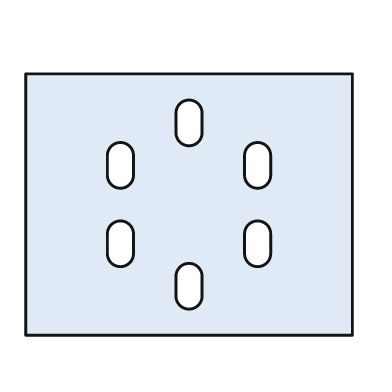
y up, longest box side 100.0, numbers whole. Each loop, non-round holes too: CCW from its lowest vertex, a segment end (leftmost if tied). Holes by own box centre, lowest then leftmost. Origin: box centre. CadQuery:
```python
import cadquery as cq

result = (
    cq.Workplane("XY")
    .moveTo(-50.0, -40.0)
    .lineTo(50.0, -40.0)
    .lineTo(50.0, 40.0)
    .lineTo(-50.0, 40.0)
    .close()
    .moveTo(-4.0, -28.0)
    .threePointArc((0.0, -32.0), (4.0, -28.0))
    .lineTo(4.0, -22.0)
    .threePointArc((0.0, -18.0), (-4.0, -22.0))
    .close()
    .moveTo(-25.0, -15.0)
    .threePointArc((-21.0, -19.0), (-17.0, -15.0))
    .lineTo(-17.0, -9.0)
    .threePointArc((-21.0, -5.0), (-25.0, -9.0))
    .close()
    .moveTo(17.0, -15.0)
    .threePointArc((21.0, -19.0), (25.0, -15.0))
    .lineTo(25.0, -9.0)
    .threePointArc((21.0, -5.0), (17.0, -9.0))
    .close()
    .moveTo(-25.0, 9.0)
    .threePointArc((-21.0, 5.0), (-17.0, 9.0))
    .lineTo(-17.0, 15.0)
    .threePointArc((-21.0, 19.0), (-25.0, 15.0))
    .close()
    .moveTo(17.0, 9.0)
    .threePointArc((21.0, 5.0), (25.0, 9.0))
    .lineTo(25.0, 15.0)
    .threePointArc((21.0, 19.0), (17.0, 15.0))
    .close()
    .moveTo(-4.0, 22.0)
    .threePointArc((0.0, 18.0), (4.0, 22.0))
    .lineTo(4.0, 28.0)
    .threePointArc((0.0, 32.0), (-4.0, 28.0))
    .close()
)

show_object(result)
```